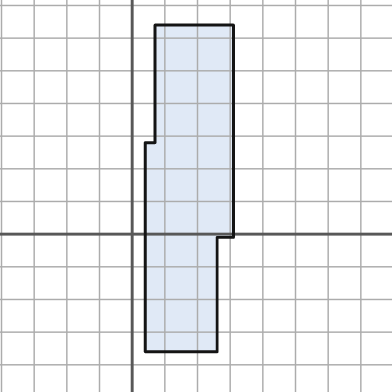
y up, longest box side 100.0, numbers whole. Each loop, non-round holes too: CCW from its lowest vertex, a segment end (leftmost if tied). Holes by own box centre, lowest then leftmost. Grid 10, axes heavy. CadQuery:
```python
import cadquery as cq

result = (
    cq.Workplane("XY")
    .moveTo(4.0, -36.0)
    .lineTo(26.0, -36.0)
    .lineTo(26.0, -1.0)
    .lineTo(31.0, -1.0)
    .lineTo(31.0, 64.0)
    .lineTo(7.0, 64.0)
    .lineTo(7.0, 28.0)
    .lineTo(4.0, 28.0)
    .close()
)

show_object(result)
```